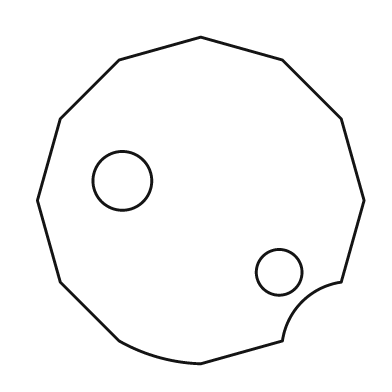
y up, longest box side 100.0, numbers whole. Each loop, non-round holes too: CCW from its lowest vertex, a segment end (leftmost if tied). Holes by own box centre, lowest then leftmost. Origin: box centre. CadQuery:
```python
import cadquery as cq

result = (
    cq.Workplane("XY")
    .moveTo(0.0, -50.0)
    .lineTo(25.0, -43.0)
    .threePointArc((31.0, -31.0), (43.0, -25.0))
    .lineTo(50.0, 0.0)
    .lineTo(43.0, 25.0)
    .lineTo(25.0, 43.0)
    .lineTo(0.0, 50.0)
    .lineTo(-25.0, 43.0)
    .lineTo(-43.0, 25.0)
    .lineTo(-50.0, 0.0)
    .lineTo(-43.0, -25.0)
    .lineTo(-25.0, -43.0)
    .threePointArc((-13.0, -48.0), (0.0, -50.0))
    .close()
    .moveTo(24.0, -22.0)
    .circle(7.0)
    .moveTo(-24.0, 6.0)
    .circle(9.0)
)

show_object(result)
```